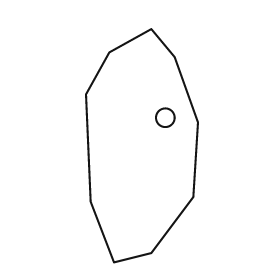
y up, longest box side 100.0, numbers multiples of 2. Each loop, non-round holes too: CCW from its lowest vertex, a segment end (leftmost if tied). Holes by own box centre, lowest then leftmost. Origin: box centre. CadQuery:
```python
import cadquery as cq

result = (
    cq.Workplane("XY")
    .moveTo(-12.0, -50.0)
    .lineTo(4.0, -46.0)
    .lineTo(22.0, -22.0)
    .lineTo(24.0, 10.0)
    .lineTo(14.0, 38.0)
    .lineTo(4.0, 50.0)
    .lineTo(-14.0, 40.0)
    .lineTo(-24.0, 22.0)
    .lineTo(-22.0, -24.0)
    .close()
    .moveTo(10.0, 12.0)
    .circle(4.0)
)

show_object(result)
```